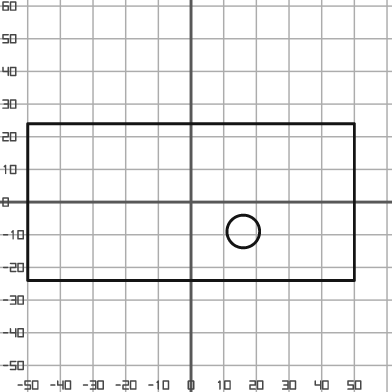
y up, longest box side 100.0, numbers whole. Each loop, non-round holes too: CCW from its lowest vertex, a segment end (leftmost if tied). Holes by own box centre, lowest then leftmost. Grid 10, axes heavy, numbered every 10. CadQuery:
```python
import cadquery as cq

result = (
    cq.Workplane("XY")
    .moveTo(-50.0, -24.0)
    .lineTo(50.0, -24.0)
    .lineTo(50.0, 24.0)
    .lineTo(-50.0, 24.0)
    .close()
    .moveTo(16.0, -9.0)
    .circle(5.0)
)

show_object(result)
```